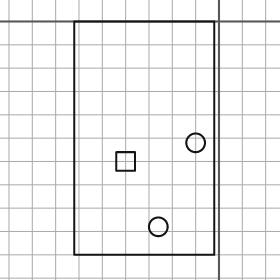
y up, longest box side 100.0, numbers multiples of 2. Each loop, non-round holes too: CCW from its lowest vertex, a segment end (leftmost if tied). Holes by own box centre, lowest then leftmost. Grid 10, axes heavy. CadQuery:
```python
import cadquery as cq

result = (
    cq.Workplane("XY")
    .moveTo(-62.0, -100.0)
    .lineTo(-2.0, -100.0)
    .lineTo(-2.0, 0.0)
    .lineTo(-62.0, 0.0)
    .close()
    .moveTo(-26.0, -88.0)
    .circle(4.0)
    .moveTo(-44.0, -64.0)
    .lineTo(-36.0, -64.0)
    .lineTo(-36.0, -56.0)
    .lineTo(-44.0, -56.0)
    .close()
    .moveTo(-10.0, -52.0)
    .circle(4.0)
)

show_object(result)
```